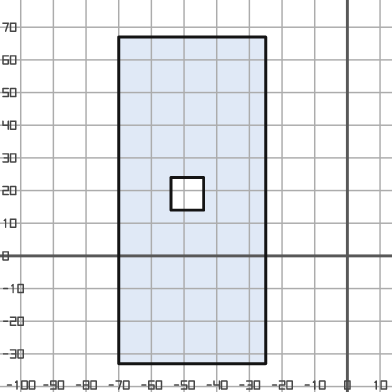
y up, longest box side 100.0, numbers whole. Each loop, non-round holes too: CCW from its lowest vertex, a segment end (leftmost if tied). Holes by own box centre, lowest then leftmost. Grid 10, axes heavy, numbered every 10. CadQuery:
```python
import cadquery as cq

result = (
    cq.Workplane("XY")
    .moveTo(-70.0, -33.0)
    .lineTo(-25.0, -33.0)
    .lineTo(-25.0, 67.0)
    .lineTo(-70.0, 67.0)
    .close()
    .moveTo(-54.0, 14.0)
    .lineTo(-44.0, 14.0)
    .lineTo(-44.0, 24.0)
    .lineTo(-54.0, 24.0)
    .close()
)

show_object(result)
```